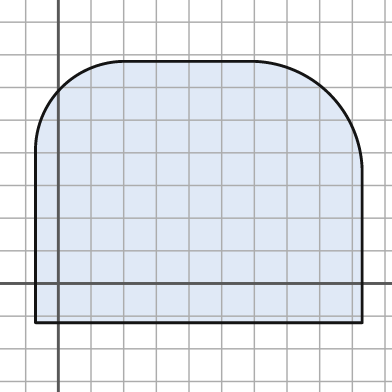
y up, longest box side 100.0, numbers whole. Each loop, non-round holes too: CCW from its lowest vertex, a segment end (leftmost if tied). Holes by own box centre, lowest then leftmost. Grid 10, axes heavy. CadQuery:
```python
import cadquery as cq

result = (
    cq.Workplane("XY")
    .moveTo(-7.0, -12.0)
    .lineTo(93.0, -12.0)
    .lineTo(93.0, 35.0)
    .threePointArc((83.0, 58.0), (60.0, 68.0))
    .lineTo(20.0, 68.0)
    .threePointArc((1.0, 60.0), (-7.0, 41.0))
    .close()
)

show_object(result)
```